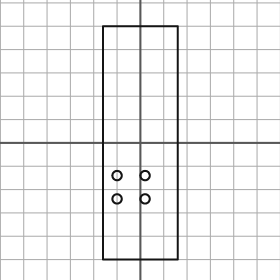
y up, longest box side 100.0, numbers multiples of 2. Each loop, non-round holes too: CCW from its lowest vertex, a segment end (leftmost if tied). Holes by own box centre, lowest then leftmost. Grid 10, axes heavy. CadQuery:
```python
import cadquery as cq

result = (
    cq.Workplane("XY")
    .moveTo(-16.0, -50.0)
    .lineTo(16.0, -50.0)
    .lineTo(16.0, 50.0)
    .lineTo(-16.0, 50.0)
    .close()
    .moveTo(-10.0, -24.0)
    .circle(2.0)
    .moveTo(2.0, -24.0)
    .circle(2.0)
    .moveTo(-10.0, -14.0)
    .circle(2.0)
    .moveTo(2.0, -14.0)
    .circle(2.0)
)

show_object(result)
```